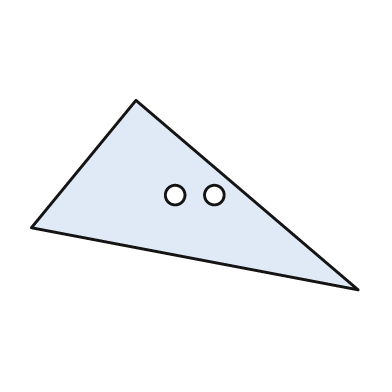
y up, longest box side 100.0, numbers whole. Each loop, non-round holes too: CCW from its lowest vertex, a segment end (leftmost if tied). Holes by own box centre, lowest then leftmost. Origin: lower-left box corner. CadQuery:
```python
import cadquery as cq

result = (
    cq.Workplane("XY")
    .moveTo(100.0, 0.0)
    .lineTo(32.0, 58.0)
    .lineTo(0.0, 19.0)
    .close()
    .moveTo(44.0, 29.0)
    .circle(3.0)
    .moveTo(56.0, 29.0)
    .circle(3.0)
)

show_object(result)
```